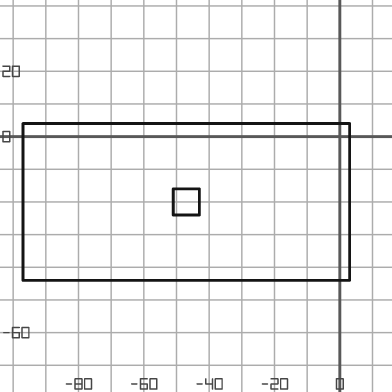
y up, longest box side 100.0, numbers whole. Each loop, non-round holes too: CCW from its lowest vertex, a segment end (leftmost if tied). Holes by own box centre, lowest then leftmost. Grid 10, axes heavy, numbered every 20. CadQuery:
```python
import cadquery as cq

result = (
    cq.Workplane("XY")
    .moveTo(-97.0, -44.0)
    .lineTo(3.0, -44.0)
    .lineTo(3.0, 4.0)
    .lineTo(-97.0, 4.0)
    .close()
    .moveTo(-51.0, -24.0)
    .lineTo(-43.0, -24.0)
    .lineTo(-43.0, -16.0)
    .lineTo(-51.0, -16.0)
    .close()
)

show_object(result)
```